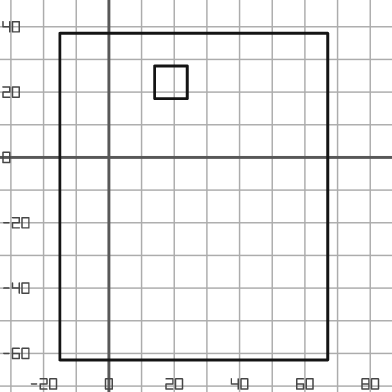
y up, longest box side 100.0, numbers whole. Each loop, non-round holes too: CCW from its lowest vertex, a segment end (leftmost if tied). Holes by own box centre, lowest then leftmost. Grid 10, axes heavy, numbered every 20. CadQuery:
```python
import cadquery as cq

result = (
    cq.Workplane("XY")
    .moveTo(-15.0, -62.0)
    .lineTo(67.0, -62.0)
    .lineTo(67.0, 38.0)
    .lineTo(-15.0, 38.0)
    .close()
    .moveTo(14.0, 18.0)
    .lineTo(24.0, 18.0)
    .lineTo(24.0, 28.0)
    .lineTo(14.0, 28.0)
    .close()
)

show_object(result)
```